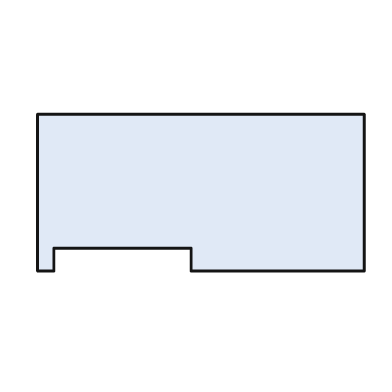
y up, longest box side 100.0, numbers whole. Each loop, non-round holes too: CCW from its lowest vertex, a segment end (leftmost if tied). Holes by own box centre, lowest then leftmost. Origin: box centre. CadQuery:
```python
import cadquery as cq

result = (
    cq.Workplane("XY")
    .moveTo(-50.0, -24.0)
    .lineTo(-45.0, -24.0)
    .lineTo(-45.0, -17.0)
    .lineTo(-3.0, -17.0)
    .lineTo(-3.0, -24.0)
    .lineTo(50.0, -24.0)
    .lineTo(50.0, 24.0)
    .lineTo(-50.0, 24.0)
    .close()
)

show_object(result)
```